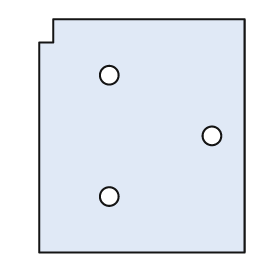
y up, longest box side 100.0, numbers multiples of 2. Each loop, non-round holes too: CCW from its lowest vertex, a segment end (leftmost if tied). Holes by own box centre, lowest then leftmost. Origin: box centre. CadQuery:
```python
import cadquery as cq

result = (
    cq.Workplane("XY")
    .moveTo(-44.0, -50.0)
    .lineTo(44.0, -50.0)
    .lineTo(44.0, 50.0)
    .lineTo(-38.0, 50.0)
    .lineTo(-38.0, 40.0)
    .lineTo(-44.0, 40.0)
    .close()
    .moveTo(-14.0, -26.0)
    .circle(4.0)
    .moveTo(30.0, 0.0)
    .circle(4.0)
    .moveTo(-14.0, 26.0)
    .circle(4.0)
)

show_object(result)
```